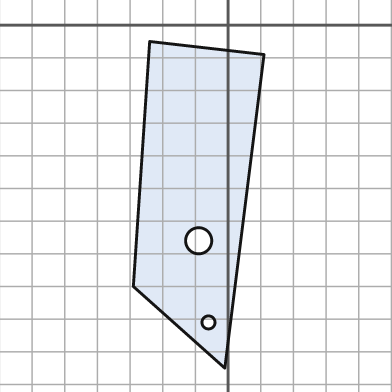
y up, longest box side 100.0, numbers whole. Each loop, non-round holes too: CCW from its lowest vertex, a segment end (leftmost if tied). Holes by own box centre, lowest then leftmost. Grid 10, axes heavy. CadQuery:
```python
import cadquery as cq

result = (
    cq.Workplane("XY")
    .moveTo(-1.0, -105.0)
    .lineTo(11.0, -9.0)
    .lineTo(-24.0, -5.0)
    .lineTo(-29.0, -80.0)
    .close()
    .moveTo(-6.0, -91.0)
    .circle(2.0)
    .moveTo(-9.0, -66.0)
    .circle(4.0)
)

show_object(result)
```